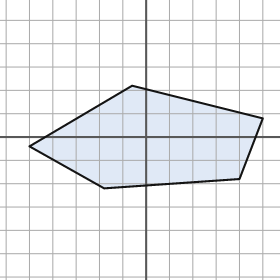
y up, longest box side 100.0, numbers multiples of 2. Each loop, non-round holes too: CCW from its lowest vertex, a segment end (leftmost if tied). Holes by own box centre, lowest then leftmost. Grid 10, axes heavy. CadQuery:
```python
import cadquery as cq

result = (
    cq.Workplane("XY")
    .moveTo(-18.0, -22.0)
    .lineTo(40.0, -18.0)
    .lineTo(50.0, 8.0)
    .lineTo(-6.0, 22.0)
    .lineTo(-50.0, -4.0)
    .close()
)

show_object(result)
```